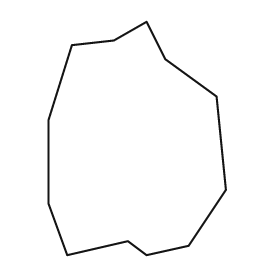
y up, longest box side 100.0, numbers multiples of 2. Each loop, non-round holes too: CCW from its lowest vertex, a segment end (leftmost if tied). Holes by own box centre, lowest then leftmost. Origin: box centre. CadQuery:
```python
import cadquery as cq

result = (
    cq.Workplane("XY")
    .moveTo(-30.0, -50.0)
    .lineTo(-4.0, -44.0)
    .lineTo(4.0, -50.0)
    .lineTo(22.0, -46.0)
    .lineTo(38.0, -22.0)
    .lineTo(34.0, 18.0)
    .lineTo(12.0, 34.0)
    .lineTo(4.0, 50.0)
    .lineTo(-10.0, 42.0)
    .lineTo(-28.0, 40.0)
    .lineTo(-38.0, 8.0)
    .lineTo(-38.0, -28.0)
    .close()
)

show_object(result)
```